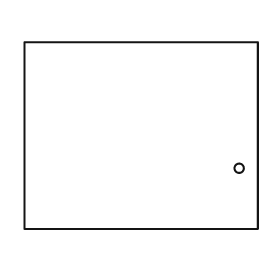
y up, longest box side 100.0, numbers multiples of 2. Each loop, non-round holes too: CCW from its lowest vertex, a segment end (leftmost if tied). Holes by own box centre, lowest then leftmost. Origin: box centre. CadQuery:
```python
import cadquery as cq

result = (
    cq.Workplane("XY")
    .moveTo(-50.0, -40.0)
    .lineTo(50.0, -40.0)
    .lineTo(50.0, 40.0)
    .lineTo(-50.0, 40.0)
    .close()
    .moveTo(42.0, -14.0)
    .circle(2.0)
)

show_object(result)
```